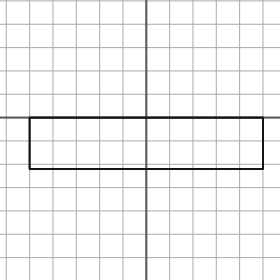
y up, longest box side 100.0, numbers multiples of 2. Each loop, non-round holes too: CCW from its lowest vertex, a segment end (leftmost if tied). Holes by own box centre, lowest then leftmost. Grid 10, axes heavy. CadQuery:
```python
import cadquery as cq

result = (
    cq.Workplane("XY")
    .moveTo(-50.0, -22.0)
    .lineTo(50.0, -22.0)
    .lineTo(50.0, 0.0)
    .lineTo(-50.0, 0.0)
    .close()
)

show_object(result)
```